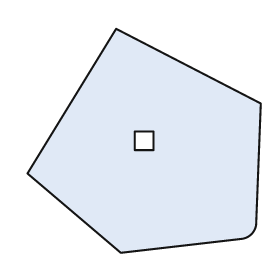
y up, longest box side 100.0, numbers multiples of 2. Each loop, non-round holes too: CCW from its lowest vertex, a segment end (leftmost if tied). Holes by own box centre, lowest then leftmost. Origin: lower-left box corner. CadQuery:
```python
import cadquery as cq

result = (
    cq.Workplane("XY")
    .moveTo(40.0, 0.0)
    .lineTo(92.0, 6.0)
    .threePointArc((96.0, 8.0), (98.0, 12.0))
    .lineTo(100.0, 64.0)
    .lineTo(38.0, 96.0)
    .lineTo(0.0, 34.0)
    .close()
    .moveTo(46.0, 44.0)
    .lineTo(54.0, 44.0)
    .lineTo(54.0, 52.0)
    .lineTo(46.0, 52.0)
    .close()
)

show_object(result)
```